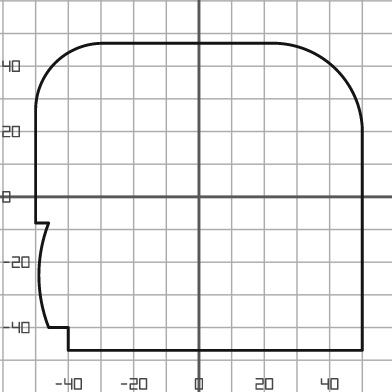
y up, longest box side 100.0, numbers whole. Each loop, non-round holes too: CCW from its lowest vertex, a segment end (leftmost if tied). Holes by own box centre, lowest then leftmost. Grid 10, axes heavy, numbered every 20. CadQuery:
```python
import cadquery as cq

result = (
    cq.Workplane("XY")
    .moveTo(-40.0, -47.0)
    .lineTo(50.0, -47.0)
    .lineTo(50.0, 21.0)
    .threePointArc((42.0, 39.0), (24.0, 47.0))
    .lineTo(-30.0, 47.0)
    .threePointArc((-44.0, 41.0), (-50.0, 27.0))
    .lineTo(-50.0, -8.0)
    .lineTo(-46.0, -8.0)
    .threePointArc((-49.0, -24.0), (-46.0, -40.0))
    .lineTo(-40.0, -40.0)
    .close()
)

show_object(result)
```